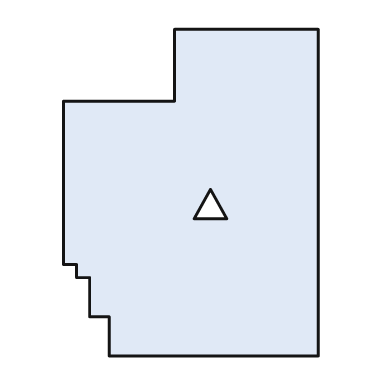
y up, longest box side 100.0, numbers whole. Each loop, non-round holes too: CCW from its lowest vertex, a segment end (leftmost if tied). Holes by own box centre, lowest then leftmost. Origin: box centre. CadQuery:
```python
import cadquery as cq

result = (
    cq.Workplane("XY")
    .moveTo(-25.0, -50.0)
    .lineTo(39.0, -50.0)
    .lineTo(39.0, 50.0)
    .lineTo(-5.0, 50.0)
    .lineTo(-5.0, 28.0)
    .lineTo(-39.0, 28.0)
    .lineTo(-39.0, -22.0)
    .lineTo(-35.0, -22.0)
    .lineTo(-35.0, -26.0)
    .lineTo(-31.0, -26.0)
    .lineTo(-31.0, -38.0)
    .lineTo(-25.0, -38.0)
    .close()
    .moveTo(1.0, -8.0)
    .lineTo(11.0, -8.0)
    .lineTo(6.0, 1.0)
    .close()
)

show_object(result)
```